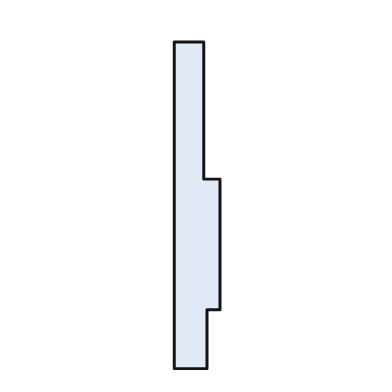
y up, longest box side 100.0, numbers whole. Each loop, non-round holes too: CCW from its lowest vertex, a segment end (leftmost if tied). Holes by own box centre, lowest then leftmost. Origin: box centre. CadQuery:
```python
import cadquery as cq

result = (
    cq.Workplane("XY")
    .moveTo(-7.0, -50.0)
    .lineTo(3.0, -50.0)
    .lineTo(3.0, -32.0)
    .lineTo(7.0, -32.0)
    .lineTo(7.0, 8.0)
    .lineTo(2.0, 8.0)
    .lineTo(2.0, 50.0)
    .lineTo(-7.0, 50.0)
    .close()
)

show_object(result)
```